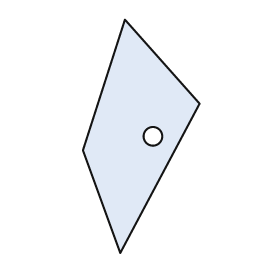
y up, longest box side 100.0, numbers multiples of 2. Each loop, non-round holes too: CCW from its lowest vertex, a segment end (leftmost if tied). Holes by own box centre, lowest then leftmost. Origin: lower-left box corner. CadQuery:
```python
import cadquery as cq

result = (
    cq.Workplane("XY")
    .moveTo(16.0, 0.0)
    .lineTo(50.0, 64.0)
    .lineTo(18.0, 100.0)
    .lineTo(0.0, 44.0)
    .close()
    .moveTo(30.0, 50.0)
    .circle(4.0)
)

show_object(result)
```